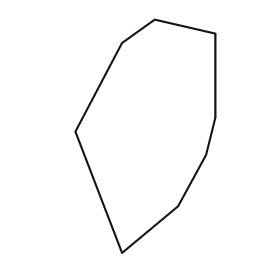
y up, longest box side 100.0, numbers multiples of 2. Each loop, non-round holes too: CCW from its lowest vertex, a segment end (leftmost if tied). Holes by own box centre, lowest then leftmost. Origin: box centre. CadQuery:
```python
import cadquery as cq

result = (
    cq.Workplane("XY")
    .moveTo(-10.0, -50.0)
    .lineTo(14.0, -30.0)
    .lineTo(26.0, -8.0)
    .lineTo(30.0, 8.0)
    .lineTo(30.0, 44.0)
    .lineTo(4.0, 50.0)
    .lineTo(-10.0, 40.0)
    .lineTo(-30.0, 2.0)
    .close()
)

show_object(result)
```